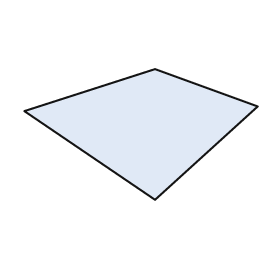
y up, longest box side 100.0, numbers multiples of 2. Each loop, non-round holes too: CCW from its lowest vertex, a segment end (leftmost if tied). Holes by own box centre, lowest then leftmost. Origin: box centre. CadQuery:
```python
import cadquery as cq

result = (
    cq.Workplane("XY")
    .moveTo(6.0, -28.0)
    .lineTo(50.0, 12.0)
    .lineTo(6.0, 28.0)
    .lineTo(-50.0, 10.0)
    .close()
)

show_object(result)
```